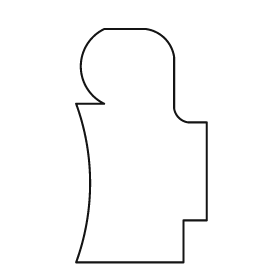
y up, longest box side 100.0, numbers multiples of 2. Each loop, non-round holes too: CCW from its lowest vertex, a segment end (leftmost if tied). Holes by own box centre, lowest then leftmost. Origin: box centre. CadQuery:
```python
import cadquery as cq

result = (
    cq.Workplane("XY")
    .moveTo(-28.0, -50.0)
    .lineTo(18.0, -50.0)
    .lineTo(18.0, -32.0)
    .lineTo(28.0, -32.0)
    .lineTo(28.0, 10.0)
    .lineTo(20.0, 10.0)
    .threePointArc((16.0, 12.0), (14.0, 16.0))
    .lineTo(14.0, 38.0)
    .threePointArc((10.0, 46.0), (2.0, 50.0))
    .lineTo(-16.0, 50.0)
    .threePointArc((-26.0, 34.0), (-16.0, 18.0))
    .lineTo(-28.0, 18.0)
    .threePointArc((-22.0, -16.0), (-28.0, -50.0))
    .close()
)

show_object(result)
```